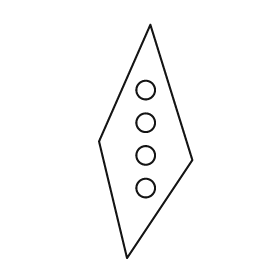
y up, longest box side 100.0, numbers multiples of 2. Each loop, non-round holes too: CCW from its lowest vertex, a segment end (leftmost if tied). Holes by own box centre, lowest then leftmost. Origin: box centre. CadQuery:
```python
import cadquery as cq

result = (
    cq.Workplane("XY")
    .moveTo(-8.0, -50.0)
    .lineTo(20.0, -8.0)
    .lineTo(2.0, 50.0)
    .lineTo(-20.0, 0.0)
    .close()
    .moveTo(0.0, -20.0)
    .circle(4.0)
    .moveTo(0.0, -6.0)
    .circle(4.0)
    .moveTo(0.0, 8.0)
    .circle(4.0)
    .moveTo(0.0, 22.0)
    .circle(4.0)
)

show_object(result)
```